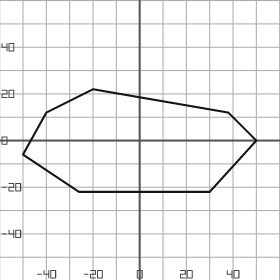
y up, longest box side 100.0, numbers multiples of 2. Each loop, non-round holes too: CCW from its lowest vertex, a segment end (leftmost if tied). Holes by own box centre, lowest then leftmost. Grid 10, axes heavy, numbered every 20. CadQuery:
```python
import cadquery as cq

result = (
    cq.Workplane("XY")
    .moveTo(-26.0, -22.0)
    .lineTo(30.0, -22.0)
    .lineTo(50.0, 0.0)
    .lineTo(38.0, 12.0)
    .lineTo(-20.0, 22.0)
    .lineTo(-40.0, 12.0)
    .lineTo(-50.0, -6.0)
    .close()
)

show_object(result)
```